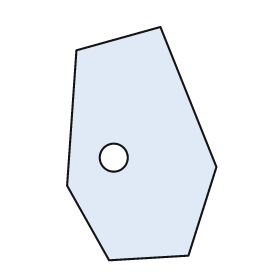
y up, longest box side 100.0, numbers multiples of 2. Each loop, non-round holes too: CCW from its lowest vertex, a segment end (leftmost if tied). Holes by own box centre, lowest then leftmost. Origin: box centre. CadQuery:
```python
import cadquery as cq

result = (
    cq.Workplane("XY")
    .moveTo(-14.0, -50.0)
    .lineTo(20.0, -48.0)
    .lineTo(32.0, -10.0)
    .lineTo(8.0, 50.0)
    .lineTo(-28.0, 40.0)
    .lineTo(-32.0, -18.0)
    .close()
    .moveTo(-12.0, -6.0)
    .circle(6.0)
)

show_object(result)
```